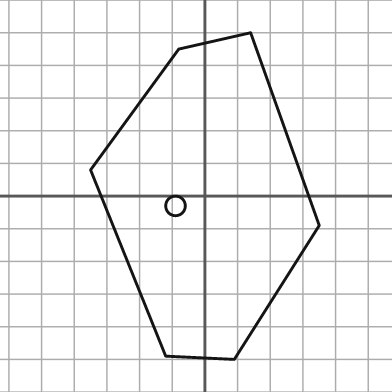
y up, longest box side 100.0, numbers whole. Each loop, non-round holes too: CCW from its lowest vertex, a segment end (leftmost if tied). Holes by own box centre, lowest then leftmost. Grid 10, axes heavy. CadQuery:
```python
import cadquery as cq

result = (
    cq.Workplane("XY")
    .moveTo(9.0, -50.0)
    .lineTo(35.0, -9.0)
    .lineTo(14.0, 50.0)
    .lineTo(-8.0, 45.0)
    .lineTo(-35.0, 8.0)
    .lineTo(-12.0, -49.0)
    .close()
    .moveTo(-9.0, -3.0)
    .circle(3.0)
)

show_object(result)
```